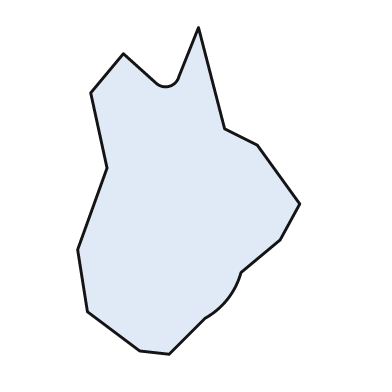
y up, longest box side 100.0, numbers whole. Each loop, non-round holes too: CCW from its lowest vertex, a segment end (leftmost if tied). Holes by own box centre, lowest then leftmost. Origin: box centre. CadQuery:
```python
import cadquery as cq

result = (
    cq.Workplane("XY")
    .moveTo(-6.0, -50.0)
    .lineTo(5.0, -39.0)
    .threePointArc((12.0, -33.0), (16.0, -25.0))
    .lineTo(28.0, -15.0)
    .lineTo(34.0, -4.0)
    .lineTo(21.0, 14.0)
    .lineTo(11.0, 19.0)
    .lineTo(3.0, 50.0)
    .lineTo(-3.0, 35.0)
    .threePointArc((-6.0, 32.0), (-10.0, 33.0))
    .lineTo(-20.0, 42.0)
    .lineTo(-30.0, 30.0)
    .lineTo(-25.0, 7.0)
    .lineTo(-34.0, -18.0)
    .lineTo(-31.0, -37.0)
    .lineTo(-15.0, -49.0)
    .close()
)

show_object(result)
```